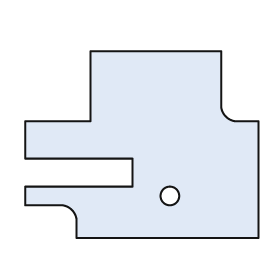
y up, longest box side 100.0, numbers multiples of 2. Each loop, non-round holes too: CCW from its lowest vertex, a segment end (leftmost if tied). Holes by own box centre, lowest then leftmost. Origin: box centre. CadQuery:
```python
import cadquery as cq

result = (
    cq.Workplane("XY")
    .moveTo(-28.0, -40.0)
    .lineTo(50.0, -40.0)
    .lineTo(50.0, 10.0)
    .lineTo(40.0, 10.0)
    .threePointArc((36.0, 12.0), (34.0, 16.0))
    .lineTo(34.0, 40.0)
    .lineTo(-22.0, 40.0)
    .lineTo(-22.0, 10.0)
    .lineTo(-50.0, 10.0)
    .lineTo(-50.0, -6.0)
    .lineTo(-4.0, -6.0)
    .lineTo(-4.0, -18.0)
    .lineTo(-50.0, -18.0)
    .lineTo(-50.0, -26.0)
    .lineTo(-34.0, -26.0)
    .threePointArc((-30.0, -28.0), (-28.0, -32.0))
    .close()
    .moveTo(12.0, -22.0)
    .circle(4.0)
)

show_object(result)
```